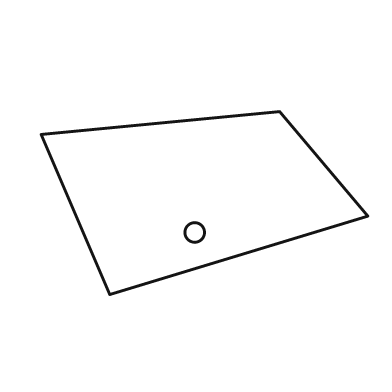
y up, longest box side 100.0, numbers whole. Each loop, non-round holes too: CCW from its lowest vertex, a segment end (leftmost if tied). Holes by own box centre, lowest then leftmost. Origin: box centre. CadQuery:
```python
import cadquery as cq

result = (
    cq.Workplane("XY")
    .moveTo(-29.0, -28.0)
    .lineTo(50.0, -4.0)
    .lineTo(23.0, 28.0)
    .lineTo(-50.0, 21.0)
    .close()
    .moveTo(-3.0, -9.0)
    .circle(3.0)
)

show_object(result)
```